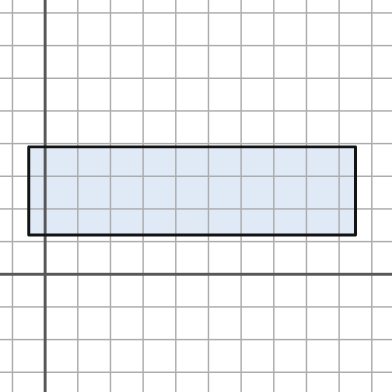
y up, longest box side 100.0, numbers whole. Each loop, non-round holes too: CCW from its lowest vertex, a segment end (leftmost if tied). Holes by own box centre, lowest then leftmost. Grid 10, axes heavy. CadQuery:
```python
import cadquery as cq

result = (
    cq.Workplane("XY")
    .moveTo(-5.0, 12.0)
    .lineTo(95.0, 12.0)
    .lineTo(95.0, 39.0)
    .lineTo(-5.0, 39.0)
    .close()
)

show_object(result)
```